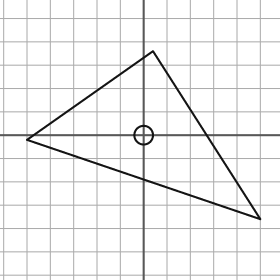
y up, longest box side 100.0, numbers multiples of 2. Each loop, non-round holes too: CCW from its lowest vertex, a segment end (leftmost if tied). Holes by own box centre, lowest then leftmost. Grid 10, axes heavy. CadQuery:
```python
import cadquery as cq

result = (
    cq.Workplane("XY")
    .moveTo(50.0, -36.0)
    .lineTo(4.0, 36.0)
    .lineTo(-50.0, -2.0)
    .close()
    .moveTo(0.0, 0.0)
    .circle(4.0)
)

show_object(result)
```